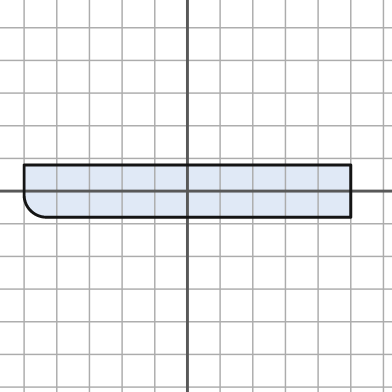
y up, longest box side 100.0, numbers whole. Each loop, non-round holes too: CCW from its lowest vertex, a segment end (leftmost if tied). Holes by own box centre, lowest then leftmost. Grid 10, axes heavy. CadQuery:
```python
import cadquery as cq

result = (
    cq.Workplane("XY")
    .moveTo(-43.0, -8.0)
    .lineTo(50.0, -8.0)
    .lineTo(50.0, 8.0)
    .lineTo(-50.0, 8.0)
    .lineTo(-50.0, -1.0)
    .threePointArc((-48.0, -6.0), (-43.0, -8.0))
    .close()
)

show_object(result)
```